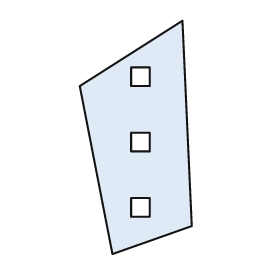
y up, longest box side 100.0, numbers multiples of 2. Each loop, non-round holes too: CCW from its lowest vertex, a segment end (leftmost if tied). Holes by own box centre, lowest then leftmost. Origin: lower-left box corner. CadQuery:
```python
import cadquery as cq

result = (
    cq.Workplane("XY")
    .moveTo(14.0, 0.0)
    .lineTo(48.0, 12.0)
    .lineTo(44.0, 100.0)
    .lineTo(0.0, 72.0)
    .close()
    .moveTo(22.0, 16.0)
    .lineTo(30.0, 16.0)
    .lineTo(30.0, 24.0)
    .lineTo(22.0, 24.0)
    .close()
    .moveTo(22.0, 44.0)
    .lineTo(30.0, 44.0)
    .lineTo(30.0, 52.0)
    .lineTo(22.0, 52.0)
    .close()
    .moveTo(22.0, 72.0)
    .lineTo(30.0, 72.0)
    .lineTo(30.0, 80.0)
    .lineTo(22.0, 80.0)
    .close()
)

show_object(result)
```